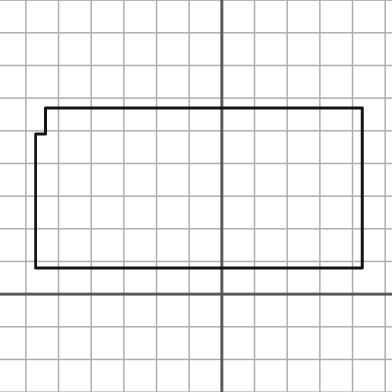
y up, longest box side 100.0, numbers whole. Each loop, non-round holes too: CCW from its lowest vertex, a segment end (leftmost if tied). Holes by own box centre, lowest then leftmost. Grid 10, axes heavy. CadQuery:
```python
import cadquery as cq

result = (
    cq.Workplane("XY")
    .moveTo(-57.0, 8.0)
    .lineTo(43.0, 8.0)
    .lineTo(43.0, 57.0)
    .lineTo(-54.0, 57.0)
    .lineTo(-54.0, 49.0)
    .lineTo(-57.0, 49.0)
    .close()
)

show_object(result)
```